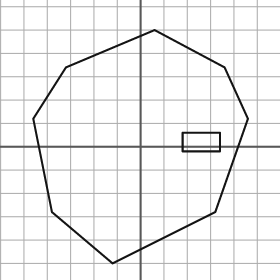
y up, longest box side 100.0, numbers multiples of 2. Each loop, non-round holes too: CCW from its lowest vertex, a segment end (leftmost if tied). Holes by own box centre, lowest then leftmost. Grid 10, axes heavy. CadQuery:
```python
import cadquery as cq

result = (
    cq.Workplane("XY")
    .moveTo(-12.0, -50.0)
    .lineTo(32.0, -28.0)
    .lineTo(46.0, 12.0)
    .lineTo(36.0, 34.0)
    .lineTo(6.0, 50.0)
    .lineTo(-32.0, 34.0)
    .lineTo(-46.0, 12.0)
    .lineTo(-38.0, -28.0)
    .close()
    .moveTo(18.0, -2.0)
    .lineTo(34.0, -2.0)
    .lineTo(34.0, 6.0)
    .lineTo(18.0, 6.0)
    .close()
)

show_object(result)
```